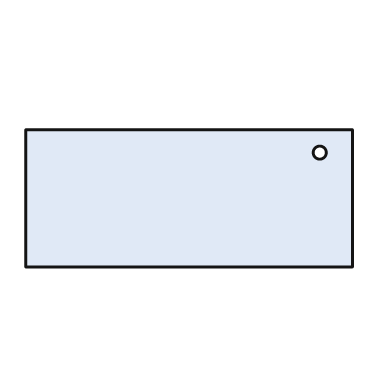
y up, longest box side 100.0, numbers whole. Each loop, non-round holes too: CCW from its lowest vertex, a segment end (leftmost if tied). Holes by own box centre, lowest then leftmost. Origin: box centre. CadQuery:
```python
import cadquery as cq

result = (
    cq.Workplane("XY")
    .moveTo(-50.0, -21.0)
    .lineTo(50.0, -21.0)
    .lineTo(50.0, 21.0)
    .lineTo(-50.0, 21.0)
    .close()
    .moveTo(40.0, 14.0)
    .circle(2.0)
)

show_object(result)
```